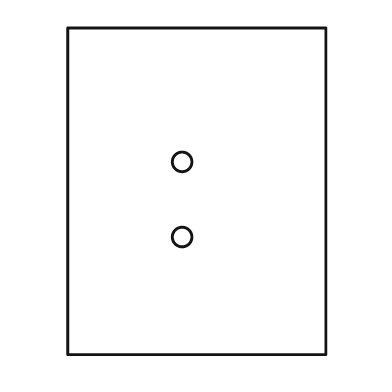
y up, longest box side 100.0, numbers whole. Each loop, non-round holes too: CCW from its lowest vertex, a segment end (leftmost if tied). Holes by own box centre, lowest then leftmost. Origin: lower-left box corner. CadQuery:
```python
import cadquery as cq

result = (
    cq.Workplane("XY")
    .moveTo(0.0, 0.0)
    .lineTo(79.0, 0.0)
    .lineTo(79.0, 100.0)
    .lineTo(0.0, 100.0)
    .close()
    .moveTo(35.0, 36.0)
    .circle(3.0)
    .moveTo(35.0, 59.0)
    .circle(3.0)
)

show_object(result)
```